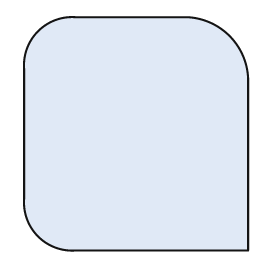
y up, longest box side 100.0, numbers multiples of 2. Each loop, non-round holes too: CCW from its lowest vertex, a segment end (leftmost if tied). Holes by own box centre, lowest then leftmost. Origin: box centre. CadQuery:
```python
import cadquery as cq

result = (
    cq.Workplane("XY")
    .moveTo(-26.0, -50.0)
    .lineTo(48.0, -50.0)
    .lineTo(48.0, 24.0)
    .threePointArc((40.0, 42.0), (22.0, 50.0))
    .lineTo(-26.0, 50.0)
    .threePointArc((-42.0, 44.0), (-48.0, 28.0))
    .lineTo(-48.0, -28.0)
    .threePointArc((-42.0, -44.0), (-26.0, -50.0))
    .close()
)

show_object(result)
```